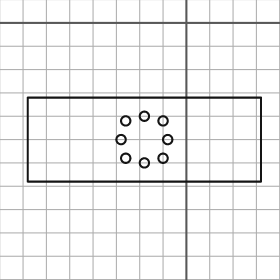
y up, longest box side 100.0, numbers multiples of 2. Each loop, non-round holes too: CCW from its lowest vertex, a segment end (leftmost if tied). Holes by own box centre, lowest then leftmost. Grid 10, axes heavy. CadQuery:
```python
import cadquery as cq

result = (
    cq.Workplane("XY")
    .moveTo(-68.0, -68.0)
    .lineTo(32.0, -68.0)
    .lineTo(32.0, -32.0)
    .lineTo(-68.0, -32.0)
    .close()
    .moveTo(-18.0, -60.0)
    .circle(2.0)
    .moveTo(-26.0, -58.0)
    .circle(2.0)
    .moveTo(-10.0, -58.0)
    .circle(2.0)
    .moveTo(-28.0, -50.0)
    .circle(2.0)
    .moveTo(-8.0, -50.0)
    .circle(2.0)
    .moveTo(-26.0, -42.0)
    .circle(2.0)
    .moveTo(-10.0, -42.0)
    .circle(2.0)
    .moveTo(-18.0, -40.0)
    .circle(2.0)
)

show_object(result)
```